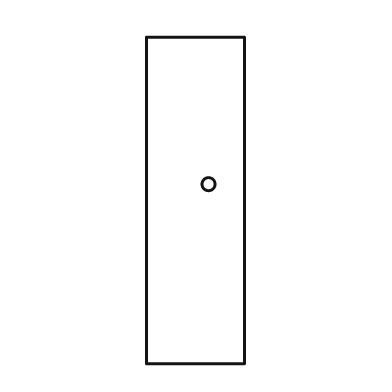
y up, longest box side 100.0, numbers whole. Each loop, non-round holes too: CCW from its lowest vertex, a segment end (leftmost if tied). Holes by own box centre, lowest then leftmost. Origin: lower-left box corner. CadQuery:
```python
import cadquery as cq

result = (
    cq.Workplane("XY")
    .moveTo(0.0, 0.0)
    .lineTo(30.0, 0.0)
    .lineTo(30.0, 100.0)
    .lineTo(0.0, 100.0)
    .close()
    .moveTo(19.0, 55.0)
    .circle(2.0)
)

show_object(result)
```